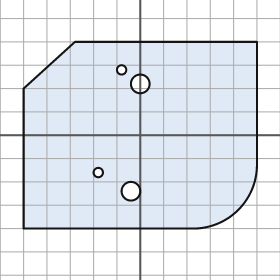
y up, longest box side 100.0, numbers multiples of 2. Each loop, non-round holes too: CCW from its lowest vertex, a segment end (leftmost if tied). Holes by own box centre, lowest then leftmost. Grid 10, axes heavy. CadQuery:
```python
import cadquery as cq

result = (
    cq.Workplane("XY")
    .moveTo(-50.0, -40.0)
    .lineTo(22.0, -40.0)
    .threePointArc((42.0, -32.0), (50.0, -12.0))
    .lineTo(50.0, 40.0)
    .lineTo(-28.0, 40.0)
    .lineTo(-50.0, 20.0)
    .close()
    .moveTo(-4.0, -24.0)
    .circle(4.0)
    .moveTo(-18.0, -16.0)
    .circle(2.0)
    .moveTo(0.0, 22.0)
    .circle(4.0)
    .moveTo(-8.0, 28.0)
    .circle(2.0)
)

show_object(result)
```